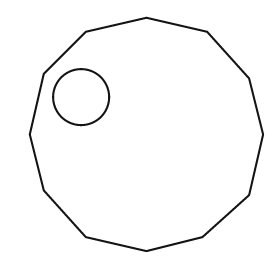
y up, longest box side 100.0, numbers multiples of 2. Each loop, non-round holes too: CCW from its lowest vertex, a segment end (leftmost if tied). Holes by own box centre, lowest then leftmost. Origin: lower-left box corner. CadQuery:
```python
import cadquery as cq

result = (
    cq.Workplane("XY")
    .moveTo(50.0, 0.0)
    .lineTo(74.0, 6.0)
    .lineTo(94.0, 24.0)
    .lineTo(100.0, 50.0)
    .lineTo(94.0, 74.0)
    .lineTo(76.0, 94.0)
    .lineTo(50.0, 100.0)
    .lineTo(24.0, 94.0)
    .lineTo(6.0, 76.0)
    .lineTo(0.0, 50.0)
    .lineTo(6.0, 26.0)
    .lineTo(24.0, 6.0)
    .close()
    .moveTo(22.0, 66.0)
    .circle(12.0)
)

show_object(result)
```